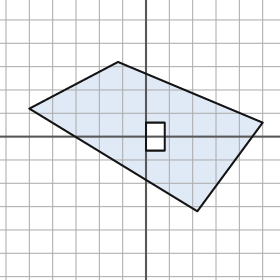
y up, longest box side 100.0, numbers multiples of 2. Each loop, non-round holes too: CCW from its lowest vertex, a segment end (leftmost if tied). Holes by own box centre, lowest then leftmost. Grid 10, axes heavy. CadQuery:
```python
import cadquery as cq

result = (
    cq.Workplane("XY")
    .moveTo(22.0, -32.0)
    .lineTo(50.0, 6.0)
    .lineTo(-12.0, 32.0)
    .lineTo(-50.0, 12.0)
    .close()
    .moveTo(0.0, -6.0)
    .lineTo(8.0, -6.0)
    .lineTo(8.0, 6.0)
    .lineTo(0.0, 6.0)
    .close()
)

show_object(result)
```